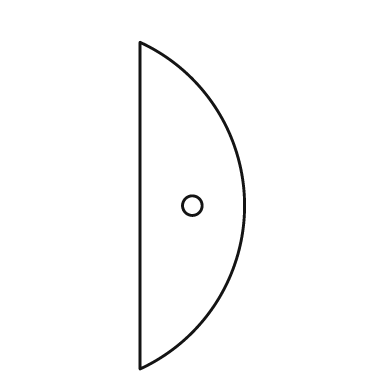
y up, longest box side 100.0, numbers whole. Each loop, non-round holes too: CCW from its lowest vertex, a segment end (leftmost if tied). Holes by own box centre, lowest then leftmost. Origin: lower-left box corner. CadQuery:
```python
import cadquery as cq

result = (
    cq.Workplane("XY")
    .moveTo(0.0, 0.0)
    .threePointArc((32.0, 50.0), (0.0, 100.0))
    .close()
    .moveTo(16.0, 50.0)
    .circle(3.0)
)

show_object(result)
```